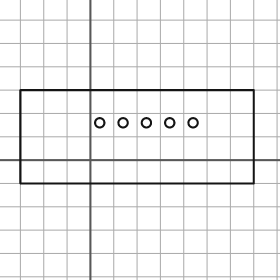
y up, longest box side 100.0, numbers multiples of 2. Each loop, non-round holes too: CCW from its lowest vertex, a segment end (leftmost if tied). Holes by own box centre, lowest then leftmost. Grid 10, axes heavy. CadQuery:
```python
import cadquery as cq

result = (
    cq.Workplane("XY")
    .moveTo(-30.0, -10.0)
    .lineTo(70.0, -10.0)
    .lineTo(70.0, 30.0)
    .lineTo(-30.0, 30.0)
    .close()
    .moveTo(4.0, 16.0)
    .circle(2.0)
    .moveTo(14.0, 16.0)
    .circle(2.0)
    .moveTo(24.0, 16.0)
    .circle(2.0)
    .moveTo(34.0, 16.0)
    .circle(2.0)
    .moveTo(44.0, 16.0)
    .circle(2.0)
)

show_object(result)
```